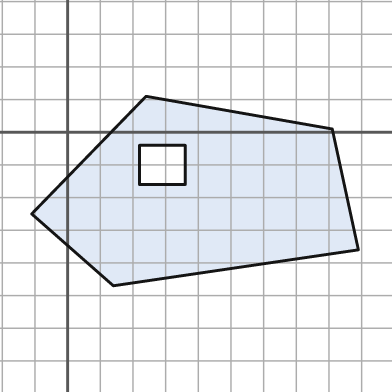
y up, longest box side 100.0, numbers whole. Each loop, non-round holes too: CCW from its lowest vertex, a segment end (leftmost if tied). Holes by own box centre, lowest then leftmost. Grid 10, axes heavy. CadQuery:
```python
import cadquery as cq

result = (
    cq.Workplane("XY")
    .moveTo(14.0, -47.0)
    .lineTo(89.0, -36.0)
    .lineTo(81.0, 1.0)
    .lineTo(24.0, 11.0)
    .lineTo(-11.0, -25.0)
    .close()
    .moveTo(22.0, -16.0)
    .lineTo(36.0, -16.0)
    .lineTo(36.0, -4.0)
    .lineTo(22.0, -4.0)
    .close()
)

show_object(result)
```